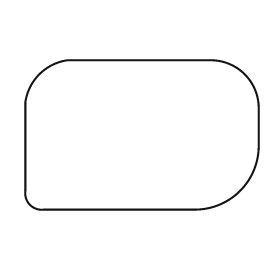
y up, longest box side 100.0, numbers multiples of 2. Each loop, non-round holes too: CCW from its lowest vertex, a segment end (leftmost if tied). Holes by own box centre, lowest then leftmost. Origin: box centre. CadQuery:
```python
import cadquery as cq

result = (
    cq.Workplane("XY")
    .moveTo(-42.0, -32.0)
    .lineTo(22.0, -32.0)
    .threePointArc((42.0, -24.0), (50.0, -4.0))
    .lineTo(50.0, 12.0)
    .threePointArc((44.0, 26.0), (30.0, 32.0))
    .lineTo(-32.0, 32.0)
    .threePointArc((-44.0, 26.0), (-50.0, 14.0))
    .lineTo(-50.0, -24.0)
    .threePointArc((-48.0, -30.0), (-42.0, -32.0))
    .close()
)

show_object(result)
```